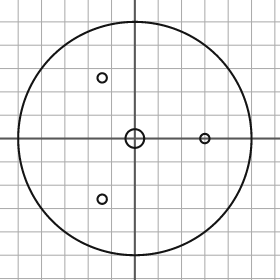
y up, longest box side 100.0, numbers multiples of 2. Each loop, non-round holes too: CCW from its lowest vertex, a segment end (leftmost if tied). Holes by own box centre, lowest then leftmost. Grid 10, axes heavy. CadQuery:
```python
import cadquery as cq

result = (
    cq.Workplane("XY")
    .moveTo(0.0, 0.0)
    .circle(50.0)
    .moveTo(-14.0, -26.0)
    .circle(2.0)
    .moveTo(0.0, 0.0)
    .circle(4.0)
    .moveTo(30.0, 0.0)
    .circle(2.0)
    .moveTo(-14.0, 26.0)
    .circle(2.0)
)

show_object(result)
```